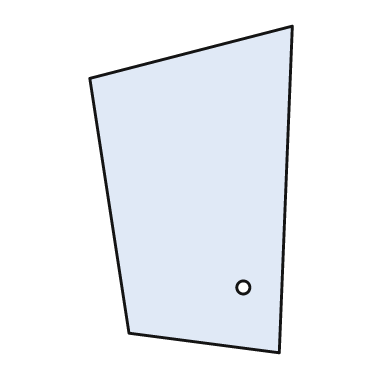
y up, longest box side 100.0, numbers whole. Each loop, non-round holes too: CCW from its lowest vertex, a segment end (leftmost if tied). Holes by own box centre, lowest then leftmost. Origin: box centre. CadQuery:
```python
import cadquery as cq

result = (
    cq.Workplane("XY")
    .moveTo(27.0, -50.0)
    .lineTo(31.0, 50.0)
    .lineTo(-31.0, 34.0)
    .lineTo(-19.0, -44.0)
    .close()
    .moveTo(16.0, -30.0)
    .circle(2.0)
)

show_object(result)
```